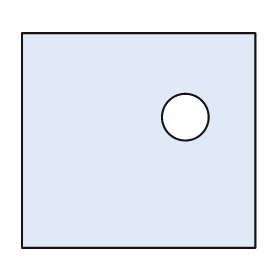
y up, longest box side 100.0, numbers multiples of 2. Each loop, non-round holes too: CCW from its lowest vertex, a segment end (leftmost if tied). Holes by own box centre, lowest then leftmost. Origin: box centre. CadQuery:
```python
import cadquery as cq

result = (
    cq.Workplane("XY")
    .moveTo(-50.0, -46.0)
    .lineTo(50.0, -46.0)
    .lineTo(50.0, 46.0)
    .lineTo(-50.0, 46.0)
    .close()
    .moveTo(20.0, 10.0)
    .circle(10.0)
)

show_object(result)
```